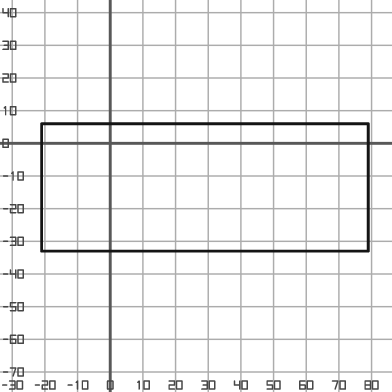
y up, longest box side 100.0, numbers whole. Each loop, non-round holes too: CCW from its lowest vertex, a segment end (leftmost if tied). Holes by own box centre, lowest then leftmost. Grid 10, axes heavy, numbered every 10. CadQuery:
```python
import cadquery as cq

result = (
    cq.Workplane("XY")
    .moveTo(-21.0, -33.0)
    .lineTo(79.0, -33.0)
    .lineTo(79.0, 6.0)
    .lineTo(-21.0, 6.0)
    .close()
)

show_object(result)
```